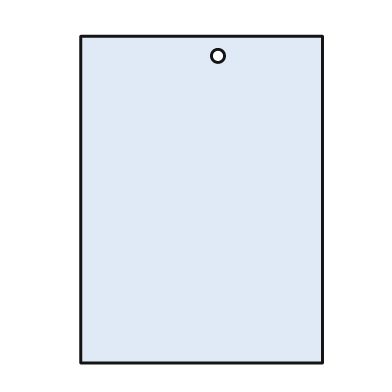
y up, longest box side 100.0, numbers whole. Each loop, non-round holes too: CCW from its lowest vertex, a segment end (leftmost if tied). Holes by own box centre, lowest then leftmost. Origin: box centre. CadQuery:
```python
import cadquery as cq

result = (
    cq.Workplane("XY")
    .moveTo(-37.0, -50.0)
    .lineTo(37.0, -50.0)
    .lineTo(37.0, 50.0)
    .lineTo(-37.0, 50.0)
    .close()
    .moveTo(5.0, 44.0)
    .circle(2.0)
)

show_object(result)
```